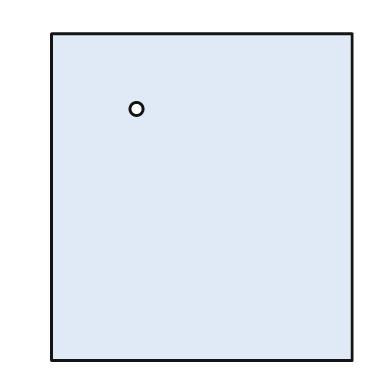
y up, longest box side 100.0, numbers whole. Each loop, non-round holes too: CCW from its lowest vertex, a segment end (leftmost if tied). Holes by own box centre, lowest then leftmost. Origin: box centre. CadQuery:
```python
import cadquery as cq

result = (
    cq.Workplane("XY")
    .moveTo(-46.0, -50.0)
    .lineTo(46.0, -50.0)
    .lineTo(46.0, 50.0)
    .lineTo(-46.0, 50.0)
    .close()
    .moveTo(-20.0, 27.0)
    .circle(2.0)
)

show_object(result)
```